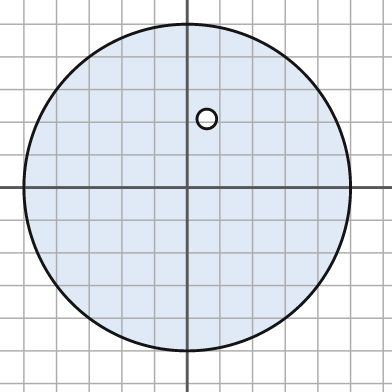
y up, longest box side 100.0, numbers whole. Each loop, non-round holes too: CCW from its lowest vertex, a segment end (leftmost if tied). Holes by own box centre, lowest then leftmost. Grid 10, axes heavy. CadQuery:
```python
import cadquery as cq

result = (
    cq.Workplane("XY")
    .moveTo(0.0, 0.0)
    .circle(50.0)
    .moveTo(6.0, 21.0)
    .circle(3.0)
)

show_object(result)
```